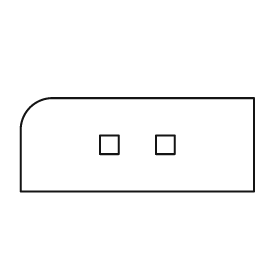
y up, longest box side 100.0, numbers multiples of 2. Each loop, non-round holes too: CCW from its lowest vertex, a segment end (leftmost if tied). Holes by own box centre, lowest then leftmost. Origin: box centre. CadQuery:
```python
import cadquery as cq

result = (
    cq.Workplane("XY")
    .moveTo(-50.0, -20.0)
    .lineTo(50.0, -20.0)
    .lineTo(50.0, 20.0)
    .lineTo(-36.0, 20.0)
    .threePointArc((-46.0, 16.0), (-50.0, 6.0))
    .close()
    .moveTo(-16.0, -4.0)
    .lineTo(-8.0, -4.0)
    .lineTo(-8.0, 4.0)
    .lineTo(-16.0, 4.0)
    .close()
    .moveTo(8.0, -4.0)
    .lineTo(16.0, -4.0)
    .lineTo(16.0, 4.0)
    .lineTo(8.0, 4.0)
    .close()
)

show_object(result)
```